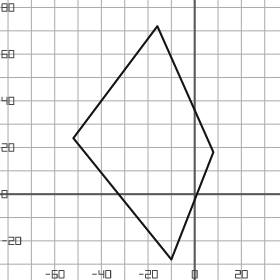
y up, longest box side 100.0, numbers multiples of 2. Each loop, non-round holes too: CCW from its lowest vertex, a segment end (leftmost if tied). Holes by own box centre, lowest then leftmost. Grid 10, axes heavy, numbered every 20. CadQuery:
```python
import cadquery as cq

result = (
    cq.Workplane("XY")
    .moveTo(-10.0, -28.0)
    .lineTo(8.0, 18.0)
    .lineTo(-16.0, 72.0)
    .lineTo(-52.0, 24.0)
    .close()
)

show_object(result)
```